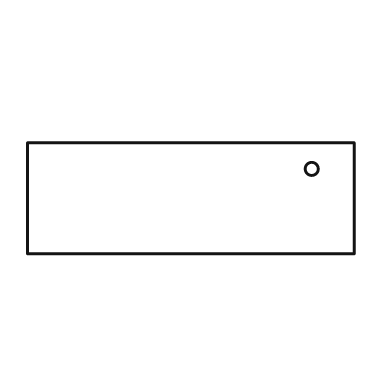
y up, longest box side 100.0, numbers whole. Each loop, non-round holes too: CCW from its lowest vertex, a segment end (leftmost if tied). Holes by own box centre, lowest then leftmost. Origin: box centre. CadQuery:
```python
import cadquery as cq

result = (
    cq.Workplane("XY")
    .moveTo(-50.0, -17.0)
    .lineTo(50.0, -17.0)
    .lineTo(50.0, 17.0)
    .lineTo(-50.0, 17.0)
    .close()
    .moveTo(37.0, 9.0)
    .circle(2.0)
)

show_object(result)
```